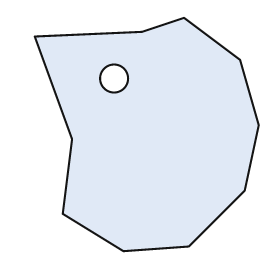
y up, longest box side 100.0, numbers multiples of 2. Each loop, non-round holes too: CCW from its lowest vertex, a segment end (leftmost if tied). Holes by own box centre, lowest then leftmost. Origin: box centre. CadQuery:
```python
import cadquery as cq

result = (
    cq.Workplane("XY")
    .moveTo(-10.0, -50.0)
    .lineTo(18.0, -48.0)
    .lineTo(42.0, -24.0)
    .lineTo(48.0, 4.0)
    .lineTo(40.0, 32.0)
    .lineTo(16.0, 50.0)
    .lineTo(-2.0, 44.0)
    .lineTo(-48.0, 42.0)
    .lineTo(-32.0, -2.0)
    .lineTo(-36.0, -34.0)
    .close()
    .moveTo(-14.0, 24.0)
    .circle(6.0)
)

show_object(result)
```